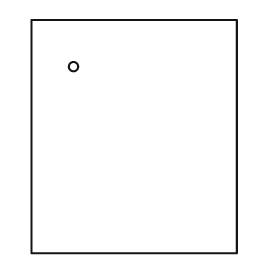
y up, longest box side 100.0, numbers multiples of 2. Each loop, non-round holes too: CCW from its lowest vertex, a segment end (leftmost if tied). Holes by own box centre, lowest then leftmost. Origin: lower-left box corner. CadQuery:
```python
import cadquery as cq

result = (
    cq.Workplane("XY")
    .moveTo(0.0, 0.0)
    .lineTo(88.0, 0.0)
    .lineTo(88.0, 100.0)
    .lineTo(0.0, 100.0)
    .close()
    .moveTo(18.0, 80.0)
    .circle(2.0)
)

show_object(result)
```